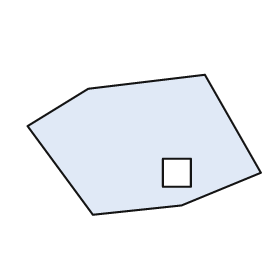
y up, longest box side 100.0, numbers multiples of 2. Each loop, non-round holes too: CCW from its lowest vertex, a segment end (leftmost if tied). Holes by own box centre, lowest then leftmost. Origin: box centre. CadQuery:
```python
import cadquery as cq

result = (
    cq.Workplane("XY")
    .moveTo(-22.0, -30.0)
    .lineTo(16.0, -26.0)
    .lineTo(50.0, -12.0)
    .lineTo(26.0, 30.0)
    .lineTo(-24.0, 24.0)
    .lineTo(-50.0, 8.0)
    .close()
    .moveTo(8.0, -18.0)
    .lineTo(20.0, -18.0)
    .lineTo(20.0, -6.0)
    .lineTo(8.0, -6.0)
    .close()
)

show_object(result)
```